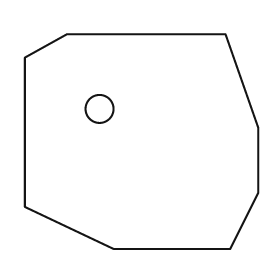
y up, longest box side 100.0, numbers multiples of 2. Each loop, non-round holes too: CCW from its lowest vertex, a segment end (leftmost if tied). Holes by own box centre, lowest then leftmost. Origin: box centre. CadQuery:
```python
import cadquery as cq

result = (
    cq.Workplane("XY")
    .moveTo(-12.0, -46.0)
    .lineTo(38.0, -46.0)
    .lineTo(50.0, -22.0)
    .lineTo(50.0, 6.0)
    .lineTo(36.0, 46.0)
    .lineTo(-32.0, 46.0)
    .lineTo(-50.0, 36.0)
    .lineTo(-50.0, -28.0)
    .close()
    .moveTo(-18.0, 14.0)
    .circle(6.0)
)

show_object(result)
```